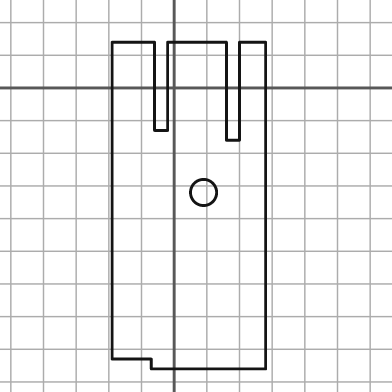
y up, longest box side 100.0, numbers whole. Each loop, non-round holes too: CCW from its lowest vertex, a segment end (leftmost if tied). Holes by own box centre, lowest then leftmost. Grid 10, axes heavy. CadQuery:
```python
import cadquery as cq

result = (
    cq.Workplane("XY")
    .moveTo(-7.0, -86.0)
    .lineTo(28.0, -86.0)
    .lineTo(28.0, 14.0)
    .lineTo(20.0, 14.0)
    .lineTo(20.0, -16.0)
    .lineTo(16.0, -16.0)
    .lineTo(16.0, 14.0)
    .lineTo(-2.0, 14.0)
    .lineTo(-2.0, -13.0)
    .lineTo(-6.0, -13.0)
    .lineTo(-6.0, 14.0)
    .lineTo(-19.0, 14.0)
    .lineTo(-19.0, -83.0)
    .lineTo(-7.0, -83.0)
    .close()
    .moveTo(9.0, -32.0)
    .circle(4.0)
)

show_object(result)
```